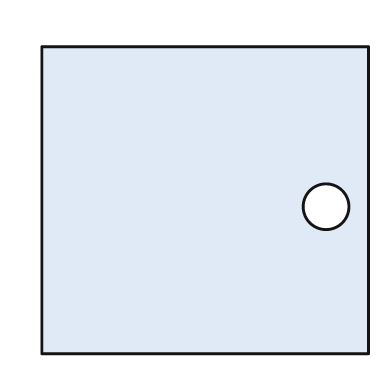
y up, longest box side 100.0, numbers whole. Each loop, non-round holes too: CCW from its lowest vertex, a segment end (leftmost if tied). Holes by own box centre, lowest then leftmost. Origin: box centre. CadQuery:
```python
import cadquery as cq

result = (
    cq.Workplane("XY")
    .moveTo(-50.0, -47.0)
    .lineTo(50.0, -47.0)
    .lineTo(50.0, 47.0)
    .lineTo(-50.0, 47.0)
    .close()
    .moveTo(37.0, -2.0)
    .circle(7.0)
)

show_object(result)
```